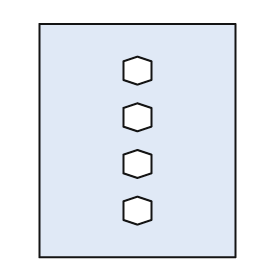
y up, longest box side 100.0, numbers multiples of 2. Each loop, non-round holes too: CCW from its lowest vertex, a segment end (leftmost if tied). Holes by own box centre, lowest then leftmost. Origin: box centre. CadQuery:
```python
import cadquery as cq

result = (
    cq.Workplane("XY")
    .moveTo(-42.0, -50.0)
    .lineTo(42.0, -50.0)
    .lineTo(42.0, 50.0)
    .lineTo(-42.0, 50.0)
    .close()
    .moveTo(0.0, -36.0)
    .lineTo(6.0, -34.0)
    .lineTo(6.0, -26.0)
    .lineTo(0.0, -24.0)
    .lineTo(-6.0, -26.0)
    .lineTo(-6.0, -34.0)
    .close()
    .moveTo(0.0, -16.0)
    .lineTo(6.0, -14.0)
    .lineTo(6.0, -6.0)
    .lineTo(0.0, -4.0)
    .lineTo(-6.0, -6.0)
    .lineTo(-6.0, -14.0)
    .close()
    .moveTo(0.0, 4.0)
    .lineTo(6.0, 6.0)
    .lineTo(6.0, 14.0)
    .lineTo(0.0, 16.0)
    .lineTo(-6.0, 14.0)
    .lineTo(-6.0, 6.0)
    .close()
    .moveTo(0.0, 24.0)
    .lineTo(6.0, 26.0)
    .lineTo(6.0, 34.0)
    .lineTo(0.0, 36.0)
    .lineTo(-6.0, 34.0)
    .lineTo(-6.0, 26.0)
    .close()
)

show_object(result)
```